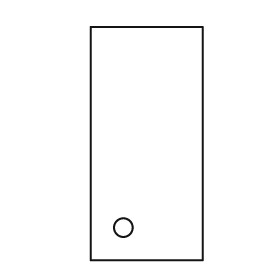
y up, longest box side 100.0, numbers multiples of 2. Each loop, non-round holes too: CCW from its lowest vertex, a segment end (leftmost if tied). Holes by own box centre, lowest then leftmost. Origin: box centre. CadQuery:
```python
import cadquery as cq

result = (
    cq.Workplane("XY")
    .moveTo(-24.0, -50.0)
    .lineTo(24.0, -50.0)
    .lineTo(24.0, 50.0)
    .lineTo(-24.0, 50.0)
    .close()
    .moveTo(-10.0, -36.0)
    .circle(4.0)
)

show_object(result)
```